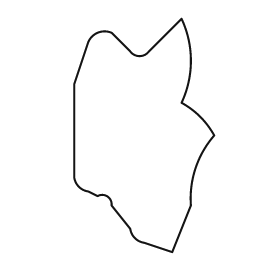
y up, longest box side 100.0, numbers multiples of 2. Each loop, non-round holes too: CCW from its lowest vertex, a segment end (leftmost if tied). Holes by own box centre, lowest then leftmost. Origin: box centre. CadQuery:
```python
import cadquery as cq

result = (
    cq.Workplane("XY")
    .moveTo(12.0, -50.0)
    .lineTo(20.0, -30.0)
    .threePointArc((22.0, -14.0), (30.0, 0.0))
    .threePointArc((24.0, 8.0), (16.0, 14.0))
    .threePointArc((20.0, 32.0), (16.0, 50.0))
    .lineTo(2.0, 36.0)
    .threePointArc((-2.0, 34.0), (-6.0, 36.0))
    .lineTo(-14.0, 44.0)
    .threePointArc((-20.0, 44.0), (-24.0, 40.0))
    .lineTo(-30.0, 22.0)
    .lineTo(-30.0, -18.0)
    .threePointArc((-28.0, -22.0), (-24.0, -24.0))
    .lineTo(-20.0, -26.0)
    .threePointArc((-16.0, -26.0), (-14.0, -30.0))
    .lineTo(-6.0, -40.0)
    .threePointArc((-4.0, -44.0), (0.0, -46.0))
    .close()
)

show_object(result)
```